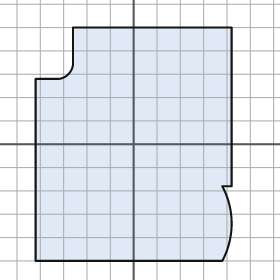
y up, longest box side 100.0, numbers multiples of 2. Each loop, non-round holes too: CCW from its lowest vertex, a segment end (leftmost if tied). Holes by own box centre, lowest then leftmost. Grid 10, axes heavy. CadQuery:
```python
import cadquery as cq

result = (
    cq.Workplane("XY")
    .moveTo(-42.0, -50.0)
    .lineTo(38.0, -50.0)
    .threePointArc((42.0, -34.0), (38.0, -18.0))
    .lineTo(42.0, -18.0)
    .lineTo(42.0, 50.0)
    .lineTo(-26.0, 50.0)
    .lineTo(-26.0, 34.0)
    .threePointArc((-28.0, 30.0), (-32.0, 28.0))
    .lineTo(-42.0, 28.0)
    .close()
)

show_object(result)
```